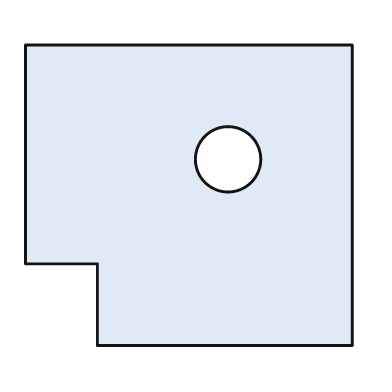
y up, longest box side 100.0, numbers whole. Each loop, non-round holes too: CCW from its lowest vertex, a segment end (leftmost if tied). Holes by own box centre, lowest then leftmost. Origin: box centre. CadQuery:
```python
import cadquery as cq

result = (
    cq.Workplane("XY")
    .moveTo(-28.0, -46.0)
    .lineTo(50.0, -46.0)
    .lineTo(50.0, 46.0)
    .lineTo(-50.0, 46.0)
    .lineTo(-50.0, -21.0)
    .lineTo(-28.0, -21.0)
    .close()
    .moveTo(12.0, 11.0)
    .circle(10.0)
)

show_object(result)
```